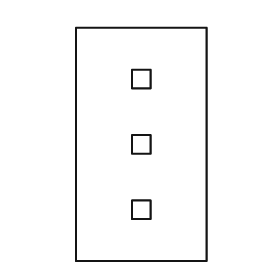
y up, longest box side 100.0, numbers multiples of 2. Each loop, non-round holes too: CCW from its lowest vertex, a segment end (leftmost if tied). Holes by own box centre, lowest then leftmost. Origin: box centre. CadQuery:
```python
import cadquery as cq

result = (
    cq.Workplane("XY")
    .moveTo(-28.0, -50.0)
    .lineTo(28.0, -50.0)
    .lineTo(28.0, 50.0)
    .lineTo(-28.0, 50.0)
    .close()
    .moveTo(-4.0, -32.0)
    .lineTo(4.0, -32.0)
    .lineTo(4.0, -24.0)
    .lineTo(-4.0, -24.0)
    .close()
    .moveTo(-4.0, -4.0)
    .lineTo(4.0, -4.0)
    .lineTo(4.0, 4.0)
    .lineTo(-4.0, 4.0)
    .close()
    .moveTo(-4.0, 24.0)
    .lineTo(4.0, 24.0)
    .lineTo(4.0, 32.0)
    .lineTo(-4.0, 32.0)
    .close()
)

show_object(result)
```